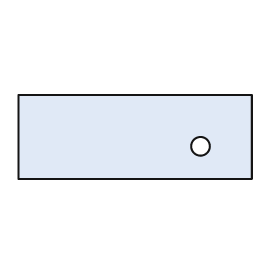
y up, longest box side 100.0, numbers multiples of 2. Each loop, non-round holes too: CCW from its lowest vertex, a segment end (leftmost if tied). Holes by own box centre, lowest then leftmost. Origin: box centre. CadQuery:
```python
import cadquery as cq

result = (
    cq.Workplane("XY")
    .moveTo(-50.0, -18.0)
    .lineTo(50.0, -18.0)
    .lineTo(50.0, 18.0)
    .lineTo(-50.0, 18.0)
    .close()
    .moveTo(28.0, -4.0)
    .circle(4.0)
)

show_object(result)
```